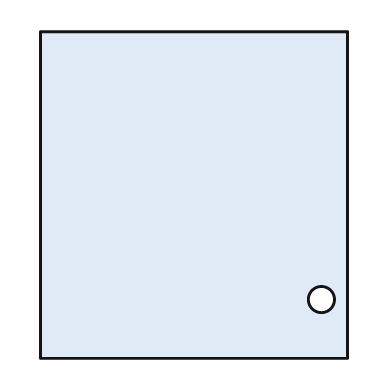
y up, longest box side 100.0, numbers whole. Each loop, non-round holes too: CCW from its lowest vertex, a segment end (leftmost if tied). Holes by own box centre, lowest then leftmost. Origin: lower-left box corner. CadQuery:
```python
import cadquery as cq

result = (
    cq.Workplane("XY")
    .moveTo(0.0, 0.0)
    .lineTo(94.0, 0.0)
    .lineTo(94.0, 100.0)
    .lineTo(0.0, 100.0)
    .close()
    .moveTo(86.0, 18.0)
    .circle(4.0)
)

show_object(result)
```